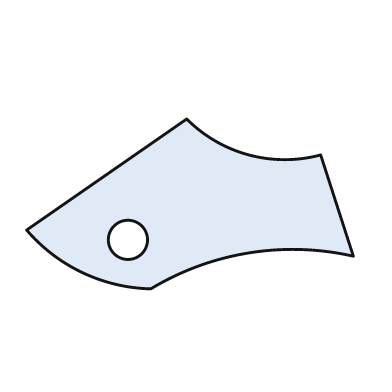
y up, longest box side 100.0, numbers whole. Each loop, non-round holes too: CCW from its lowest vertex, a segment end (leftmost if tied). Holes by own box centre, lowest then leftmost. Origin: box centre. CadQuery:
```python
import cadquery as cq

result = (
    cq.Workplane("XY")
    .moveTo(-12.0, -26.0)
    .threePointArc((18.0, -15.0), (50.0, -16.0))
    .lineTo(40.0, 15.0)
    .threePointArc((18.0, 15.0), (-1.0, 26.0))
    .lineTo(-50.0, -8.0)
    .threePointArc((-33.0, -21.0), (-12.0, -26.0))
    .close()
    .moveTo(-19.0, -11.0)
    .circle(6.0)
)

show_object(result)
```